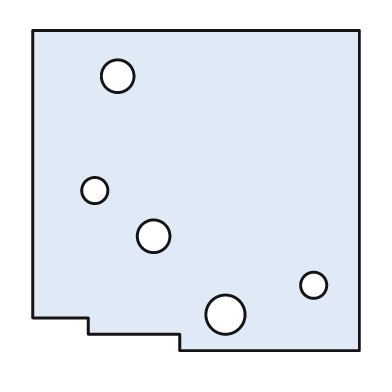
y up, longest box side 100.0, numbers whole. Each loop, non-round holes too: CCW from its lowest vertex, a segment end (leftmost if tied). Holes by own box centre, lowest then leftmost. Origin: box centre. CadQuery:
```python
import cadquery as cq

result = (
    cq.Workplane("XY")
    .moveTo(-5.0, -49.0)
    .lineTo(50.0, -49.0)
    .lineTo(50.0, 49.0)
    .lineTo(-50.0, 49.0)
    .lineTo(-50.0, -39.0)
    .lineTo(-33.0, -39.0)
    .lineTo(-33.0, -44.0)
    .lineTo(-5.0, -44.0)
    .close()
    .moveTo(9.0, -38.0)
    .circle(6.0)
    .moveTo(36.0, -29.0)
    .circle(4.0)
    .moveTo(-13.0, -14.0)
    .circle(5.0)
    .moveTo(-31.0, 0.0)
    .circle(4.0)
    .moveTo(-24.0, 35.0)
    .circle(5.0)
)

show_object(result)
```